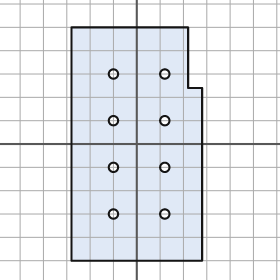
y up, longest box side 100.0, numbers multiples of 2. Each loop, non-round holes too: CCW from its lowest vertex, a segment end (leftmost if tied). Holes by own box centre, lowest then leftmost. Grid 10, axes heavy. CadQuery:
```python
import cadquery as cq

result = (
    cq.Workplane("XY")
    .moveTo(-28.0, -50.0)
    .lineTo(28.0, -50.0)
    .lineTo(28.0, 24.0)
    .lineTo(22.0, 24.0)
    .lineTo(22.0, 50.0)
    .lineTo(-28.0, 50.0)
    .close()
    .moveTo(-10.0, -30.0)
    .circle(2.0)
    .moveTo(12.0, -30.0)
    .circle(2.0)
    .moveTo(-10.0, -10.0)
    .circle(2.0)
    .moveTo(12.0, -10.0)
    .circle(2.0)
    .moveTo(-10.0, 10.0)
    .circle(2.0)
    .moveTo(12.0, 10.0)
    .circle(2.0)
    .moveTo(-10.0, 30.0)
    .circle(2.0)
    .moveTo(12.0, 30.0)
    .circle(2.0)
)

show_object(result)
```